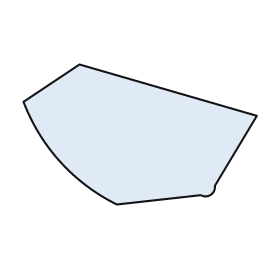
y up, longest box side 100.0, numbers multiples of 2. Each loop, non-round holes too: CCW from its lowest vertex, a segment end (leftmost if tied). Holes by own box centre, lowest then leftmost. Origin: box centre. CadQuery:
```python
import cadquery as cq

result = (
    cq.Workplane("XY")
    .moveTo(-10.0, -30.0)
    .lineTo(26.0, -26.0)
    .threePointArc((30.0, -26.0), (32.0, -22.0))
    .lineTo(50.0, 8.0)
    .lineTo(-26.0, 30.0)
    .lineTo(-50.0, 14.0)
    .threePointArc((-34.0, -12.0), (-10.0, -30.0))
    .close()
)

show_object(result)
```